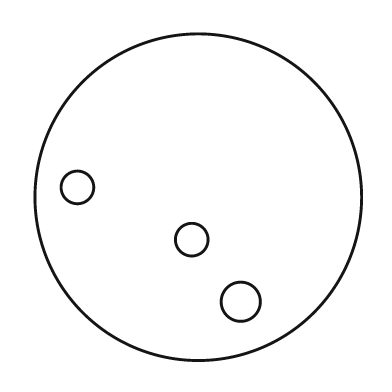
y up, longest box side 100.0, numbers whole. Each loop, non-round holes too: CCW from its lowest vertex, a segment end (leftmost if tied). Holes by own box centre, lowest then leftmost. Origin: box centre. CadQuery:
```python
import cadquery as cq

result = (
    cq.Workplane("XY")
    .moveTo(0.0, 0.0)
    .circle(50.0)
    .moveTo(13.0, -32.0)
    .circle(6.0)
    .moveTo(-2.0, -13.0)
    .circle(5.0)
    .moveTo(-37.0, 3.0)
    .circle(5.0)
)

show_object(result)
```